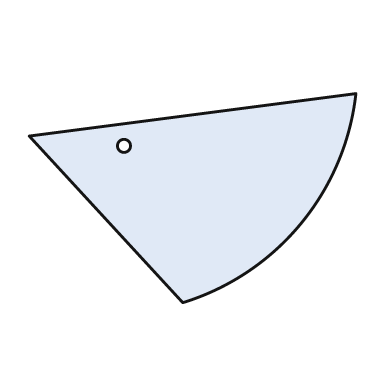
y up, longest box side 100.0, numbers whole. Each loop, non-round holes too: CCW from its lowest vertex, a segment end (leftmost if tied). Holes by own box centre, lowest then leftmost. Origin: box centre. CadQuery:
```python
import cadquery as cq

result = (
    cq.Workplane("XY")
    .moveTo(-3.0, -32.0)
    .threePointArc((33.0, -8.0), (50.0, 32.0))
    .lineTo(-50.0, 19.0)
    .close()
    .moveTo(-21.0, 16.0)
    .circle(2.0)
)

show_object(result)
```